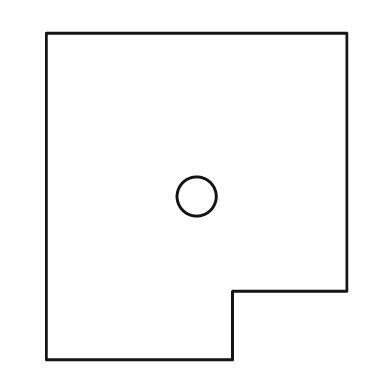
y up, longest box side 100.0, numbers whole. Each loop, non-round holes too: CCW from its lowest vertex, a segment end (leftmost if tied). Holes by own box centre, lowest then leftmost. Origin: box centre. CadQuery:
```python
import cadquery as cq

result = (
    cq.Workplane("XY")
    .moveTo(-46.0, -50.0)
    .lineTo(11.0, -50.0)
    .lineTo(11.0, -29.0)
    .lineTo(46.0, -29.0)
    .lineTo(46.0, 50.0)
    .lineTo(-46.0, 50.0)
    .close()
    .moveTo(0.0, 0.0)
    .circle(6.0)
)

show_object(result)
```